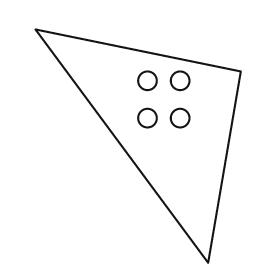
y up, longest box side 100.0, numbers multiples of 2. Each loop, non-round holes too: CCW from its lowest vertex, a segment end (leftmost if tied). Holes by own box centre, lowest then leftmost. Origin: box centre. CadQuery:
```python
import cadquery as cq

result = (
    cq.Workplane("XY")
    .moveTo(30.0, -50.0)
    .lineTo(44.0, 32.0)
    .lineTo(-44.0, 50.0)
    .close()
    .moveTo(4.0, 12.0)
    .circle(4.0)
    .moveTo(18.0, 12.0)
    .circle(4.0)
    .moveTo(4.0, 28.0)
    .circle(4.0)
    .moveTo(18.0, 28.0)
    .circle(4.0)
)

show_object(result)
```